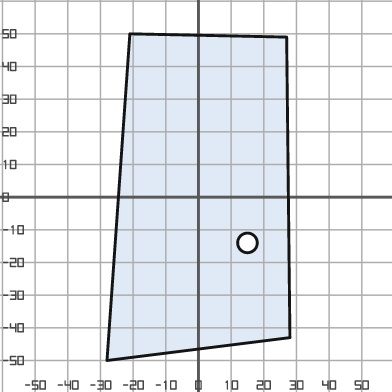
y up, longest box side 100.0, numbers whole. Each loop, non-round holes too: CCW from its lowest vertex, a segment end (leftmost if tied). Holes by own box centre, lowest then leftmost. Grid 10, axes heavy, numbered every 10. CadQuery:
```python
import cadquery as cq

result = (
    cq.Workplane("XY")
    .moveTo(-28.0, -50.0)
    .lineTo(28.0, -43.0)
    .lineTo(27.0, 49.0)
    .lineTo(-21.0, 50.0)
    .close()
    .moveTo(15.0, -14.0)
    .circle(3.0)
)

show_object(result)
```